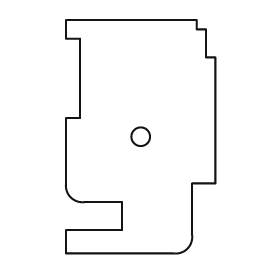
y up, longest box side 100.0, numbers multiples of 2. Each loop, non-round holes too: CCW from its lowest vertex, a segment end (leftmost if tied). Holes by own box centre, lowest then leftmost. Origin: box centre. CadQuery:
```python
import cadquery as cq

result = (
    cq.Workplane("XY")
    .moveTo(-32.0, -50.0)
    .lineTo(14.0, -50.0)
    .threePointArc((20.0, -48.0), (22.0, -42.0))
    .lineTo(22.0, -20.0)
    .lineTo(32.0, -20.0)
    .lineTo(32.0, 34.0)
    .lineTo(28.0, 34.0)
    .lineTo(28.0, 46.0)
    .lineTo(24.0, 46.0)
    .lineTo(24.0, 50.0)
    .lineTo(-32.0, 50.0)
    .lineTo(-32.0, 42.0)
    .lineTo(-26.0, 42.0)
    .lineTo(-26.0, 8.0)
    .lineTo(-32.0, 8.0)
    .lineTo(-32.0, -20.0)
    .threePointArc((-30.0, -26.0), (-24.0, -28.0))
    .lineTo(-8.0, -28.0)
    .lineTo(-8.0, -40.0)
    .lineTo(-32.0, -40.0)
    .close()
    .moveTo(0.0, 0.0)
    .circle(4.0)
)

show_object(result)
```